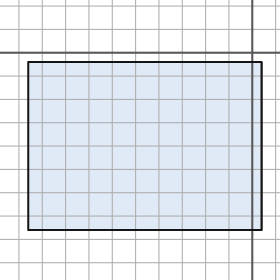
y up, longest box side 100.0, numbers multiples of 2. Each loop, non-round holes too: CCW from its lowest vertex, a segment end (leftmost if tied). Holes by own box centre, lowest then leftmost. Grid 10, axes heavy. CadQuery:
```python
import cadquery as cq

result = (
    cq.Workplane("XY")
    .moveTo(-96.0, -76.0)
    .lineTo(4.0, -76.0)
    .lineTo(4.0, -4.0)
    .lineTo(-96.0, -4.0)
    .close()
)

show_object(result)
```